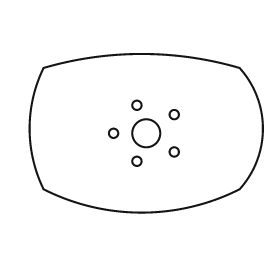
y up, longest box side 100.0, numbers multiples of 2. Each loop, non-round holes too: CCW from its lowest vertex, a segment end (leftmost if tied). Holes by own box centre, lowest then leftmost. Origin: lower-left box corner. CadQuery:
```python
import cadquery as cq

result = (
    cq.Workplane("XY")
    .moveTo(6.0, 10.0)
    .threePointArc((48.0, 0.0), (90.0, 10.0))
    .threePointArc((100.0, 36.0), (90.0, 62.0))
    .threePointArc((48.0, 68.0), (6.0, 62.0))
    .threePointArc((0.0, 36.0), (6.0, 10.0))
    .close()
    .moveTo(46.0, 22.0)
    .circle(2.0)
    .moveTo(62.0, 26.0)
    .circle(2.0)
    .moveTo(36.0, 34.0)
    .circle(2.0)
    .moveTo(50.0, 34.0)
    .circle(6.0)
    .moveTo(62.0, 42.0)
    .circle(2.0)
    .moveTo(46.0, 46.0)
    .circle(2.0)
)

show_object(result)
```